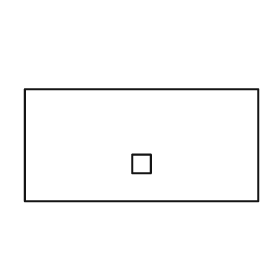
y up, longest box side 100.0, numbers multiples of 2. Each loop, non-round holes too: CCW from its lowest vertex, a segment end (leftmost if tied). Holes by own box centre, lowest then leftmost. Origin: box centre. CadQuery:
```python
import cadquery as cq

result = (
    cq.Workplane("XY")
    .moveTo(-50.0, -24.0)
    .lineTo(50.0, -24.0)
    .lineTo(50.0, 24.0)
    .lineTo(-50.0, 24.0)
    .close()
    .moveTo(-4.0, -12.0)
    .lineTo(4.0, -12.0)
    .lineTo(4.0, -4.0)
    .lineTo(-4.0, -4.0)
    .close()
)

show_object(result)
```